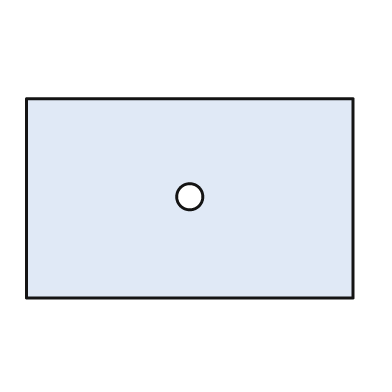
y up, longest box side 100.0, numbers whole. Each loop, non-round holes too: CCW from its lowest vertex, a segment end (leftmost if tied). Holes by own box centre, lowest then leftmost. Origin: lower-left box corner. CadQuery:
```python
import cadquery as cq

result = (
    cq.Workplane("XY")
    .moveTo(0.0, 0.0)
    .lineTo(100.0, 0.0)
    .lineTo(100.0, 61.0)
    .lineTo(0.0, 61.0)
    .close()
    .moveTo(50.0, 31.0)
    .circle(4.0)
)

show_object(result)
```